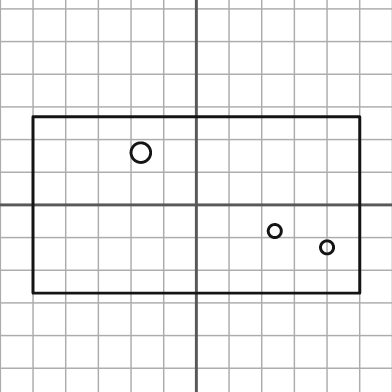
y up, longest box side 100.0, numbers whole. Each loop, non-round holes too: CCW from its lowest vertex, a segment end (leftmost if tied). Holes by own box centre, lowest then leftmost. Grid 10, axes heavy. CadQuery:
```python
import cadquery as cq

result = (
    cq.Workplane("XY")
    .moveTo(-50.0, -27.0)
    .lineTo(50.0, -27.0)
    .lineTo(50.0, 27.0)
    .lineTo(-50.0, 27.0)
    .close()
    .moveTo(40.0, -13.0)
    .circle(2.0)
    .moveTo(24.0, -8.0)
    .circle(2.0)
    .moveTo(-17.0, 16.0)
    .circle(3.0)
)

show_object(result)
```